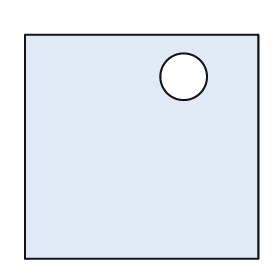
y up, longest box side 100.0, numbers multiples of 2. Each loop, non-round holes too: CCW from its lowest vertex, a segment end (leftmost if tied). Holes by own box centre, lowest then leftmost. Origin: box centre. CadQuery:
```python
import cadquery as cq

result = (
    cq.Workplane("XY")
    .moveTo(-50.0, -48.0)
    .lineTo(50.0, -48.0)
    .lineTo(50.0, 48.0)
    .lineTo(-50.0, 48.0)
    .close()
    .moveTo(18.0, 30.0)
    .circle(10.0)
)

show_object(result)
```